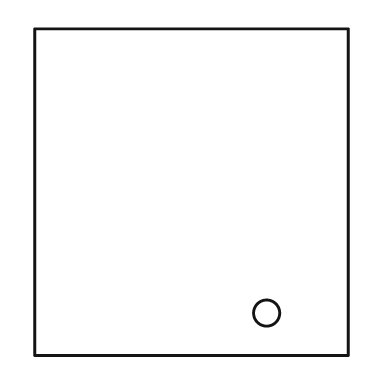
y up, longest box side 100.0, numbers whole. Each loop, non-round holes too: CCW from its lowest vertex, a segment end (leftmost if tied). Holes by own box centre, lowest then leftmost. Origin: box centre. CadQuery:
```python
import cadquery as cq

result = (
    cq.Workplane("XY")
    .moveTo(-48.0, -50.0)
    .lineTo(48.0, -50.0)
    .lineTo(48.0, 50.0)
    .lineTo(-48.0, 50.0)
    .close()
    .moveTo(23.0, -37.0)
    .circle(4.0)
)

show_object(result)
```